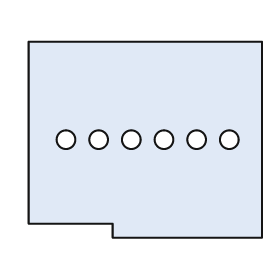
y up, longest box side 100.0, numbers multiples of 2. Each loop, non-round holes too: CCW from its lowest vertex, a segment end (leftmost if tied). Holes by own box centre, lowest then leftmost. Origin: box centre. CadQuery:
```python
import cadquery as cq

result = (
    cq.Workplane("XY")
    .moveTo(-14.0, -42.0)
    .lineTo(50.0, -42.0)
    .lineTo(50.0, 42.0)
    .lineTo(-50.0, 42.0)
    .lineTo(-50.0, -36.0)
    .lineTo(-14.0, -36.0)
    .close()
    .moveTo(-34.0, 0.0)
    .circle(4.0)
    .moveTo(-20.0, 0.0)
    .circle(4.0)
    .moveTo(-6.0, 0.0)
    .circle(4.0)
    .moveTo(8.0, 0.0)
    .circle(4.0)
    .moveTo(22.0, 0.0)
    .circle(4.0)
    .moveTo(36.0, 0.0)
    .circle(4.0)
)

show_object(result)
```